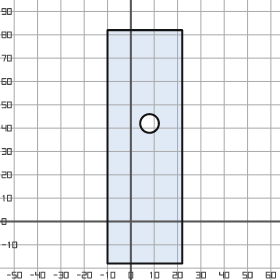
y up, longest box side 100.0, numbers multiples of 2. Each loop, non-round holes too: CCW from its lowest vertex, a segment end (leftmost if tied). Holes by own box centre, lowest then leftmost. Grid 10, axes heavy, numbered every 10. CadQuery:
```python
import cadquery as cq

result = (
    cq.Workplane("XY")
    .moveTo(-10.0, -18.0)
    .lineTo(22.0, -18.0)
    .lineTo(22.0, 82.0)
    .lineTo(-10.0, 82.0)
    .close()
    .moveTo(8.0, 42.0)
    .circle(4.0)
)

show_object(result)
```